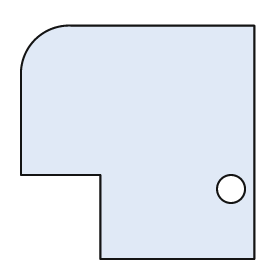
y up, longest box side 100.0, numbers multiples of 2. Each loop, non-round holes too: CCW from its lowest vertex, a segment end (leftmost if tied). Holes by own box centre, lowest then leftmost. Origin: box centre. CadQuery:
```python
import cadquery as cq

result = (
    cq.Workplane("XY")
    .moveTo(-16.0, -50.0)
    .lineTo(50.0, -50.0)
    .lineTo(50.0, 50.0)
    .lineTo(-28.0, 50.0)
    .threePointArc((-44.0, 44.0), (-50.0, 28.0))
    .lineTo(-50.0, -14.0)
    .lineTo(-16.0, -14.0)
    .close()
    .moveTo(40.0, -20.0)
    .circle(6.0)
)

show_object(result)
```